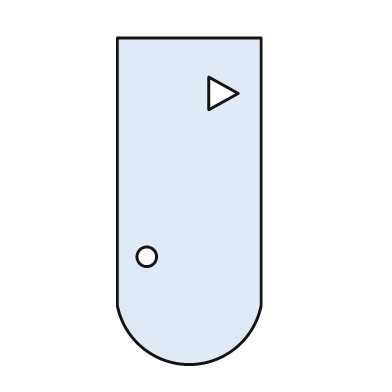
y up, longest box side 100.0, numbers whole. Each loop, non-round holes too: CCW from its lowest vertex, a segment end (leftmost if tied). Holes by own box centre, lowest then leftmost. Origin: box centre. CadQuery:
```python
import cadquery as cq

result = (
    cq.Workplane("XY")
    .moveTo(-22.0, -32.0)
    .threePointArc((0.0, -50.0), (22.0, -32.0))
    .lineTo(22.0, 50.0)
    .lineTo(-22.0, 50.0)
    .close()
    .moveTo(-13.0, -17.0)
    .circle(3.0)
    .moveTo(6.0, 28.0)
    .lineTo(15.0, 33.0)
    .lineTo(6.0, 38.0)
    .close()
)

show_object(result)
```